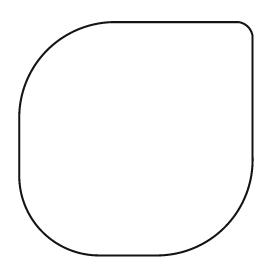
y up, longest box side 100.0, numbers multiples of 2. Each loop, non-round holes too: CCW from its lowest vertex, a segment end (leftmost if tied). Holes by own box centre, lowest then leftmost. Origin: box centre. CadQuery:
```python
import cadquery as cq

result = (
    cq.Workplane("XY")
    .moveTo(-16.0, -50.0)
    .lineTo(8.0, -50.0)
    .threePointArc((38.0, -38.0), (50.0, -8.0))
    .lineTo(50.0, 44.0)
    .threePointArc((48.0, 48.0), (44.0, 50.0))
    .lineTo(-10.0, 50.0)
    .threePointArc((-38.0, 38.0), (-50.0, 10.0))
    .lineTo(-50.0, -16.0)
    .threePointArc((-40.0, -40.0), (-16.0, -50.0))
    .close()
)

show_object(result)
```